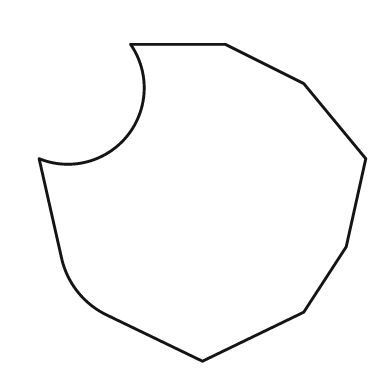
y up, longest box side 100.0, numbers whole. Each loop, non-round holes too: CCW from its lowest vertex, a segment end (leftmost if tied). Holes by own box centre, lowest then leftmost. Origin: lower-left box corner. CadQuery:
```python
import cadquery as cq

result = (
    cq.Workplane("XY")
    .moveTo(50.0, 0.0)
    .lineTo(81.0, 15.0)
    .lineTo(94.0, 35.0)
    .lineTo(100.0, 62.0)
    .lineTo(81.0, 85.0)
    .lineTo(57.0, 97.0)
    .lineTo(28.0, 97.0)
    .threePointArc((27.0, 69.0), (0.0, 62.0))
    .lineTo(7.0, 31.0)
    .threePointArc((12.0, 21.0), (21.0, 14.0))
    .close()
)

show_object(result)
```